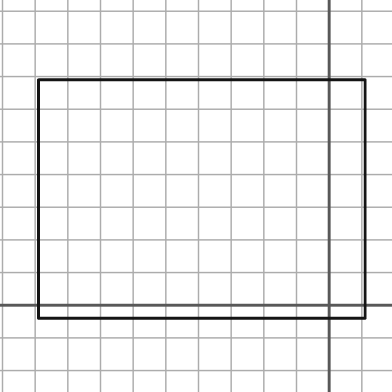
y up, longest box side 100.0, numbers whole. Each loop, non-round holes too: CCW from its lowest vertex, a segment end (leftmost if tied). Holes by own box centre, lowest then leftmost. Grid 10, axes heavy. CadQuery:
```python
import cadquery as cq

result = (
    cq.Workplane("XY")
    .moveTo(-89.0, -4.0)
    .lineTo(11.0, -4.0)
    .lineTo(11.0, 69.0)
    .lineTo(-89.0, 69.0)
    .close()
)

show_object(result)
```